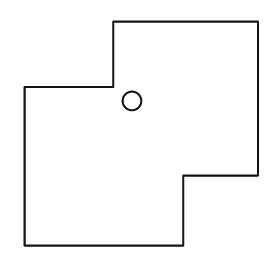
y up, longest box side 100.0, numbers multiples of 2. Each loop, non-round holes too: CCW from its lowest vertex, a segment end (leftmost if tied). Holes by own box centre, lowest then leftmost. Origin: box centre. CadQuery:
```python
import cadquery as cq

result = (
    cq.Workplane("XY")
    .moveTo(-50.0, -48.0)
    .lineTo(18.0, -48.0)
    .lineTo(18.0, -18.0)
    .lineTo(50.0, -18.0)
    .lineTo(50.0, 48.0)
    .lineTo(-12.0, 48.0)
    .lineTo(-12.0, 20.0)
    .lineTo(-50.0, 20.0)
    .close()
    .moveTo(-4.0, 14.0)
    .circle(4.0)
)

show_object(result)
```